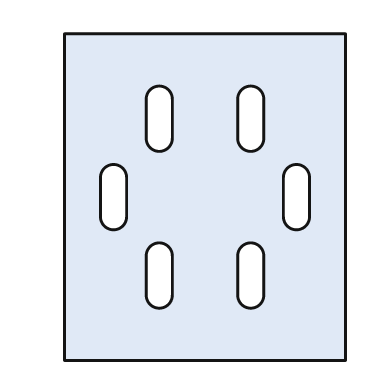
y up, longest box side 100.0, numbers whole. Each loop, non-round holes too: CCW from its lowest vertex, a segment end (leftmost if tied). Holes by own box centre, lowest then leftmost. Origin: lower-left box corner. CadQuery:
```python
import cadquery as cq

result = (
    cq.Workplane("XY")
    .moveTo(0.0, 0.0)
    .lineTo(86.0, 0.0)
    .lineTo(86.0, 100.0)
    .lineTo(0.0, 100.0)
    .close()
    .moveTo(25.0, 20.0)
    .threePointArc((29.0, 16.0), (33.0, 20.0))
    .lineTo(33.0, 32.0)
    .threePointArc((29.0, 36.0), (25.0, 32.0))
    .close()
    .moveTo(53.0, 20.0)
    .threePointArc((57.0, 16.0), (61.0, 20.0))
    .lineTo(61.0, 32.0)
    .threePointArc((57.0, 36.0), (53.0, 32.0))
    .close()
    .moveTo(11.0, 44.0)
    .threePointArc((15.0, 40.0), (19.0, 44.0))
    .lineTo(19.0, 56.0)
    .threePointArc((15.0, 60.0), (11.0, 56.0))
    .close()
    .moveTo(67.0, 44.0)
    .threePointArc((71.0, 40.0), (75.0, 44.0))
    .lineTo(75.0, 56.0)
    .threePointArc((71.0, 60.0), (67.0, 56.0))
    .close()
    .moveTo(25.0, 68.0)
    .threePointArc((29.0, 64.0), (33.0, 68.0))
    .lineTo(33.0, 80.0)
    .threePointArc((29.0, 84.0), (25.0, 80.0))
    .close()
    .moveTo(53.0, 68.0)
    .threePointArc((57.0, 64.0), (61.0, 68.0))
    .lineTo(61.0, 80.0)
    .threePointArc((57.0, 84.0), (53.0, 80.0))
    .close()
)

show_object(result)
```